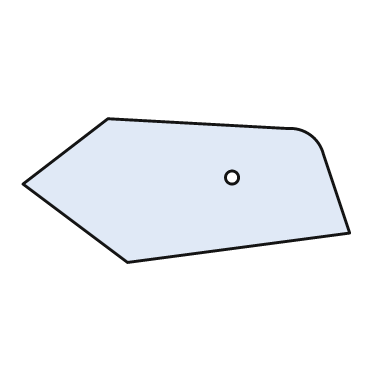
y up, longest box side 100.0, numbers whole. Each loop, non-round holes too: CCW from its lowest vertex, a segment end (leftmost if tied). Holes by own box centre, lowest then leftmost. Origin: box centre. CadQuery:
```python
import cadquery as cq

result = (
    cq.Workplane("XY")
    .moveTo(-18.0, -22.0)
    .lineTo(50.0, -13.0)
    .lineTo(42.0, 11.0)
    .threePointArc((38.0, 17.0), (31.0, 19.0))
    .lineTo(-24.0, 22.0)
    .lineTo(-50.0, 2.0)
    .close()
    .moveTo(14.0, 4.0)
    .circle(2.0)
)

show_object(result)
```